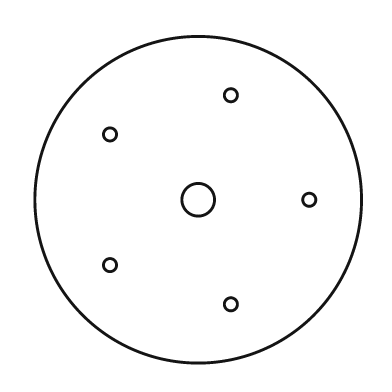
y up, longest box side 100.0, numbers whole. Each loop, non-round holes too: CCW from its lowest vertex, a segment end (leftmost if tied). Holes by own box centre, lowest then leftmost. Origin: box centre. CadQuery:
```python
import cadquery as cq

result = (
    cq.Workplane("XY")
    .moveTo(0.0, 0.0)
    .circle(50.0)
    .moveTo(10.0, -32.0)
    .circle(2.0)
    .moveTo(-27.0, -20.0)
    .circle(2.0)
    .moveTo(0.0, 0.0)
    .circle(5.0)
    .moveTo(34.0, 0.0)
    .circle(2.0)
    .moveTo(-27.0, 20.0)
    .circle(2.0)
    .moveTo(10.0, 32.0)
    .circle(2.0)
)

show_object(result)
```